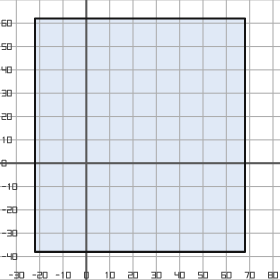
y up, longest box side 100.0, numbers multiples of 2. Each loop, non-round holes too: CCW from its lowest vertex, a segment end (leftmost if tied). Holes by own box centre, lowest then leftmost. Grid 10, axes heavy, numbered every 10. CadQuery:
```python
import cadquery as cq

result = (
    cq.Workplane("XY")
    .moveTo(-22.0, -38.0)
    .lineTo(68.0, -38.0)
    .lineTo(68.0, 62.0)
    .lineTo(-22.0, 62.0)
    .close()
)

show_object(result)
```